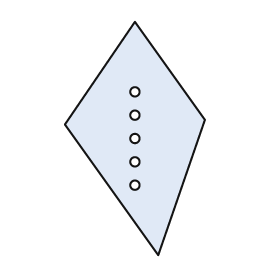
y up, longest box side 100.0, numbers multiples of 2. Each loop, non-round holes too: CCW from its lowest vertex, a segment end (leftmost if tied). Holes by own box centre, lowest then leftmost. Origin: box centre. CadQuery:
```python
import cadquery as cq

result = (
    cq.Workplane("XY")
    .moveTo(10.0, -50.0)
    .lineTo(30.0, 8.0)
    .lineTo(0.0, 50.0)
    .lineTo(-30.0, 6.0)
    .close()
    .moveTo(0.0, -20.0)
    .circle(2.0)
    .moveTo(0.0, -10.0)
    .circle(2.0)
    .moveTo(0.0, 0.0)
    .circle(2.0)
    .moveTo(0.0, 10.0)
    .circle(2.0)
    .moveTo(0.0, 20.0)
    .circle(2.0)
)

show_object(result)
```